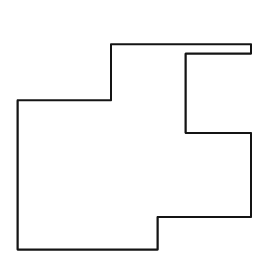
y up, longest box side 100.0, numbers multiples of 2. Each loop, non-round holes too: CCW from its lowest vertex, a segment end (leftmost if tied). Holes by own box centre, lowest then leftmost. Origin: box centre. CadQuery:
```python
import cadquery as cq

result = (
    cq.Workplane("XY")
    .moveTo(-50.0, -44.0)
    .lineTo(10.0, -44.0)
    .lineTo(10.0, -30.0)
    .lineTo(50.0, -30.0)
    .lineTo(50.0, 6.0)
    .lineTo(22.0, 6.0)
    .lineTo(22.0, 40.0)
    .lineTo(50.0, 40.0)
    .lineTo(50.0, 44.0)
    .lineTo(-10.0, 44.0)
    .lineTo(-10.0, 20.0)
    .lineTo(-50.0, 20.0)
    .close()
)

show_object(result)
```